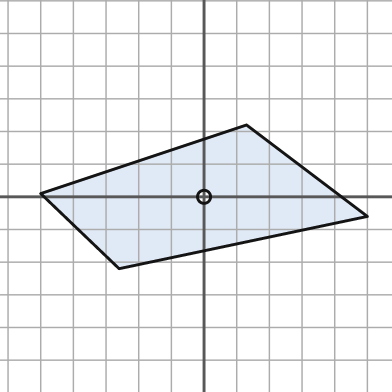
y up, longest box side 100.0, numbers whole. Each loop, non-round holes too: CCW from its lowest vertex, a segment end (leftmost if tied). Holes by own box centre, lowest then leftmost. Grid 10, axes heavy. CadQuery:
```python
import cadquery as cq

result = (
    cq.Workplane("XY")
    .moveTo(-26.0, -22.0)
    .lineTo(50.0, -6.0)
    .lineTo(13.0, 22.0)
    .lineTo(-50.0, 1.0)
    .close()
    .moveTo(0.0, 0.0)
    .circle(2.0)
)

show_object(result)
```